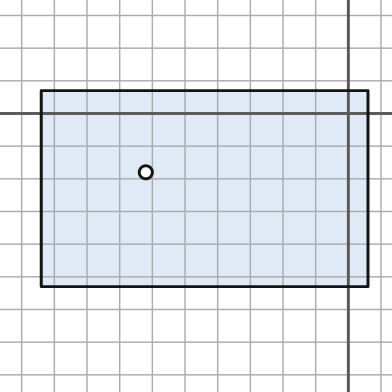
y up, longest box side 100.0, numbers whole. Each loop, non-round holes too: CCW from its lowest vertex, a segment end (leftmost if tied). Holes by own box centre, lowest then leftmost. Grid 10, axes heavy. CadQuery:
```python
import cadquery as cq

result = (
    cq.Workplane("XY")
    .moveTo(-94.0, -53.0)
    .lineTo(6.0, -53.0)
    .lineTo(6.0, 7.0)
    .lineTo(-94.0, 7.0)
    .close()
    .moveTo(-62.0, -18.0)
    .circle(2.0)
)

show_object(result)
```